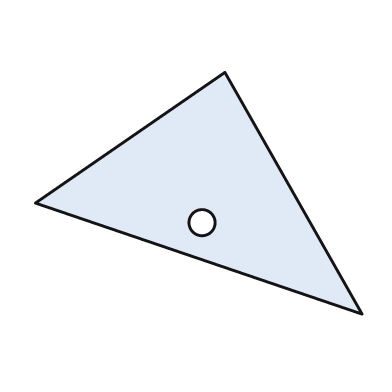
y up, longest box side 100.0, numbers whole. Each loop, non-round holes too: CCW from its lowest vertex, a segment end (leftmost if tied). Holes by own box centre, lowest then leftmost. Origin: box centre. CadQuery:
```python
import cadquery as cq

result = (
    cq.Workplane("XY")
    .moveTo(50.0, -37.0)
    .lineTo(8.0, 37.0)
    .lineTo(-50.0, -3.0)
    .close()
    .moveTo(1.0, -9.0)
    .circle(4.0)
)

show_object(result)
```